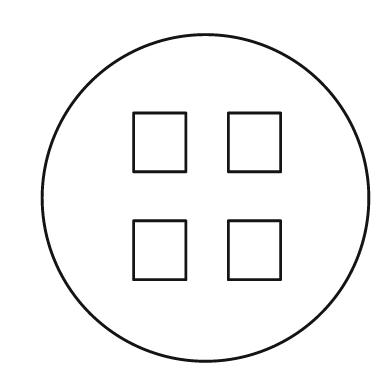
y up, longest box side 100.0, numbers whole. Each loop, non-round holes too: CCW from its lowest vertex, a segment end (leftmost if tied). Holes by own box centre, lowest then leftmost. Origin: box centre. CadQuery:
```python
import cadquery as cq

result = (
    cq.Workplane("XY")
    .moveTo(0.0, 0.0)
    .circle(50.0)
    .moveTo(-22.0, -25.0)
    .lineTo(-6.0, -25.0)
    .lineTo(-6.0, -7.0)
    .lineTo(-22.0, -7.0)
    .close()
    .moveTo(7.0, -25.0)
    .lineTo(23.0, -25.0)
    .lineTo(23.0, -7.0)
    .lineTo(7.0, -7.0)
    .close()
    .moveTo(-22.0, 8.0)
    .lineTo(-6.0, 8.0)
    .lineTo(-6.0, 26.0)
    .lineTo(-22.0, 26.0)
    .close()
    .moveTo(7.0, 8.0)
    .lineTo(23.0, 8.0)
    .lineTo(23.0, 26.0)
    .lineTo(7.0, 26.0)
    .close()
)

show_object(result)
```